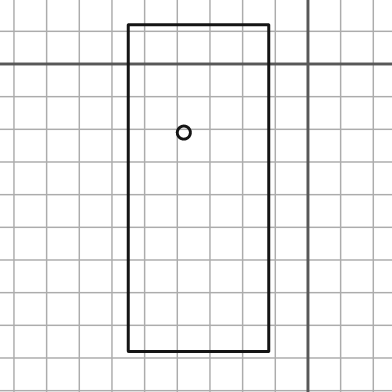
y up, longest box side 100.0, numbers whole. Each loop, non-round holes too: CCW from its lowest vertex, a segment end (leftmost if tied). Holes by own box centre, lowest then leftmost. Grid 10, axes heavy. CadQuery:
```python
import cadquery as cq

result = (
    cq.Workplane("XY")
    .moveTo(-55.0, -88.0)
    .lineTo(-12.0, -88.0)
    .lineTo(-12.0, 12.0)
    .lineTo(-55.0, 12.0)
    .close()
    .moveTo(-38.0, -21.0)
    .circle(2.0)
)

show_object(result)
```